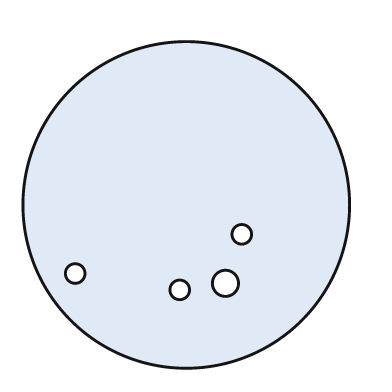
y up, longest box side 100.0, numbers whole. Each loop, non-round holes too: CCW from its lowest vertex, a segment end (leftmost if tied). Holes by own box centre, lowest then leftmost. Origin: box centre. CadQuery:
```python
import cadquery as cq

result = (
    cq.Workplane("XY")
    .moveTo(0.0, 0.0)
    .circle(50.0)
    .moveTo(-2.0, -26.0)
    .circle(3.0)
    .moveTo(12.0, -24.0)
    .circle(4.0)
    .moveTo(-34.0, -21.0)
    .circle(3.0)
    .moveTo(17.0, -9.0)
    .circle(3.0)
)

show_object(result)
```